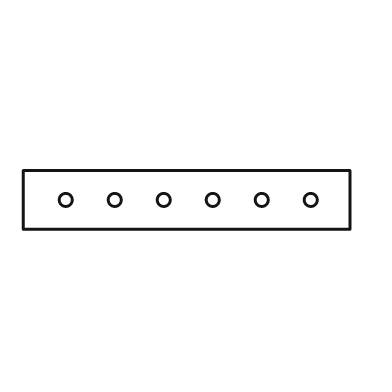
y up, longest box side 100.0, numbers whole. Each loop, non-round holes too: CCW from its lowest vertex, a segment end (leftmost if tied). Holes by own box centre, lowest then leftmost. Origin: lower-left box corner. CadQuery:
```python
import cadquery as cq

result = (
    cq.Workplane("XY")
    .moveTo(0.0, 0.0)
    .lineTo(100.0, 0.0)
    .lineTo(100.0, 18.0)
    .lineTo(0.0, 18.0)
    .close()
    .moveTo(13.0, 9.0)
    .circle(2.0)
    .moveTo(28.0, 9.0)
    .circle(2.0)
    .moveTo(43.0, 9.0)
    .circle(2.0)
    .moveTo(58.0, 9.0)
    .circle(2.0)
    .moveTo(73.0, 9.0)
    .circle(2.0)
    .moveTo(88.0, 9.0)
    .circle(2.0)
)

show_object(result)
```